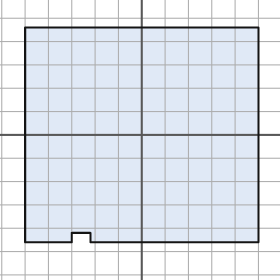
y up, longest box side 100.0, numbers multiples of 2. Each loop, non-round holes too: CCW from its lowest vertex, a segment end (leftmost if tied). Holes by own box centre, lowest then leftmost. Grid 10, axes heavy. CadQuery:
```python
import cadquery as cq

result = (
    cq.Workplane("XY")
    .moveTo(-50.0, -46.0)
    .lineTo(-30.0, -46.0)
    .lineTo(-30.0, -42.0)
    .lineTo(-22.0, -42.0)
    .lineTo(-22.0, -46.0)
    .lineTo(50.0, -46.0)
    .lineTo(50.0, 46.0)
    .lineTo(-50.0, 46.0)
    .close()
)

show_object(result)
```